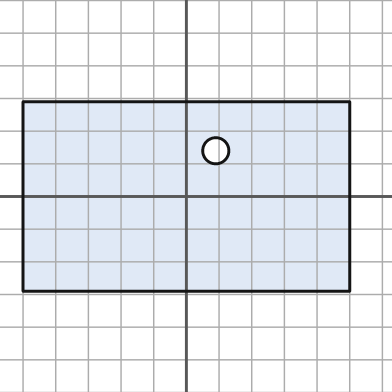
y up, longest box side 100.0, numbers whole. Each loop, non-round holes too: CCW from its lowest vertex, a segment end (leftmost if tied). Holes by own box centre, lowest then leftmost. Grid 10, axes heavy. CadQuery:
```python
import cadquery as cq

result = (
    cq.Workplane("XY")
    .moveTo(-50.0, -29.0)
    .lineTo(50.0, -29.0)
    .lineTo(50.0, 29.0)
    .lineTo(-50.0, 29.0)
    .close()
    .moveTo(9.0, 14.0)
    .circle(4.0)
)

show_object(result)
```